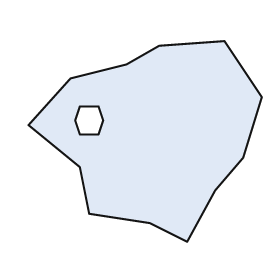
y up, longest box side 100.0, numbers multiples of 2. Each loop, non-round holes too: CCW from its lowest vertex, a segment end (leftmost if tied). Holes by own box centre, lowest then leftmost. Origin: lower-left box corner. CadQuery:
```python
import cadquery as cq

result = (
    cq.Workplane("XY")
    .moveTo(68.0, 0.0)
    .lineTo(80.0, 22.0)
    .lineTo(92.0, 36.0)
    .lineTo(100.0, 62.0)
    .lineTo(84.0, 86.0)
    .lineTo(56.0, 84.0)
    .lineTo(42.0, 76.0)
    .lineTo(18.0, 70.0)
    .lineTo(0.0, 50.0)
    .lineTo(22.0, 32.0)
    .lineTo(26.0, 12.0)
    .lineTo(52.0, 8.0)
    .close()
    .moveTo(22.0, 46.0)
    .lineTo(30.0, 46.0)
    .lineTo(32.0, 52.0)
    .lineTo(30.0, 58.0)
    .lineTo(22.0, 58.0)
    .lineTo(20.0, 52.0)
    .close()
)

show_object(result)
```